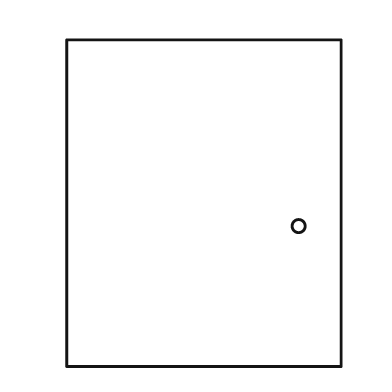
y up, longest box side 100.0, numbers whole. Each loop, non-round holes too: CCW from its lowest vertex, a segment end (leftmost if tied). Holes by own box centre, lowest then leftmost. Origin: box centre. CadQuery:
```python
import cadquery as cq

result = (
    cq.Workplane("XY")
    .moveTo(-42.0, -50.0)
    .lineTo(42.0, -50.0)
    .lineTo(42.0, 50.0)
    .lineTo(-42.0, 50.0)
    .close()
    .moveTo(29.0, -7.0)
    .circle(2.0)
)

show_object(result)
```